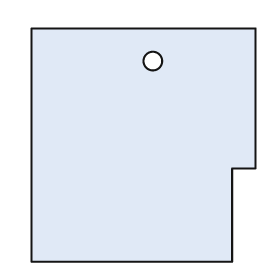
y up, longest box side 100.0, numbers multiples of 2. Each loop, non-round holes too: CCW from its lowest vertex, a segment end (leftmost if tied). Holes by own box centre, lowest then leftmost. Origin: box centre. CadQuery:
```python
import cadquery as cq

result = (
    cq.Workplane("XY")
    .moveTo(-48.0, -50.0)
    .lineTo(38.0, -50.0)
    .lineTo(38.0, -10.0)
    .lineTo(48.0, -10.0)
    .lineTo(48.0, 50.0)
    .lineTo(-48.0, 50.0)
    .close()
    .moveTo(4.0, 36.0)
    .circle(4.0)
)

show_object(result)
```